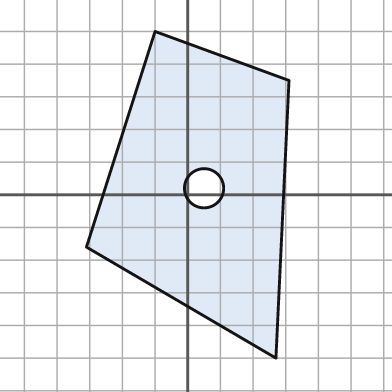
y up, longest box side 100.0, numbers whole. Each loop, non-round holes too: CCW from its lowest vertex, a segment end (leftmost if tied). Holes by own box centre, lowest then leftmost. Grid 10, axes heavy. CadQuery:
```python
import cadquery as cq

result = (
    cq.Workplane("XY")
    .moveTo(27.0, -50.0)
    .lineTo(31.0, 35.0)
    .lineTo(-10.0, 50.0)
    .lineTo(-31.0, -16.0)
    .close()
    .moveTo(5.0, 2.0)
    .circle(6.0)
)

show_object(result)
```